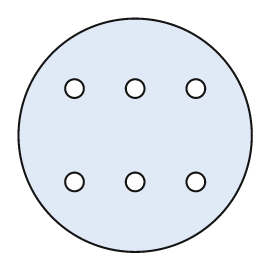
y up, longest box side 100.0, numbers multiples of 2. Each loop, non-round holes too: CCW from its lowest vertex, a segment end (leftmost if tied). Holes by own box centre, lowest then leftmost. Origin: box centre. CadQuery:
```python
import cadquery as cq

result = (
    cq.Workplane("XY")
    .moveTo(0.0, 0.0)
    .circle(50.0)
    .moveTo(-26.0, -20.0)
    .circle(4.0)
    .moveTo(0.0, -20.0)
    .circle(4.0)
    .moveTo(26.0, -20.0)
    .circle(4.0)
    .moveTo(-26.0, 20.0)
    .circle(4.0)
    .moveTo(0.0, 20.0)
    .circle(4.0)
    .moveTo(26.0, 20.0)
    .circle(4.0)
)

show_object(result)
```